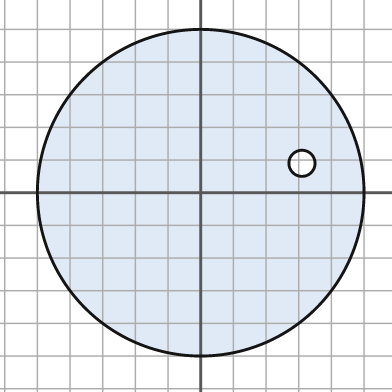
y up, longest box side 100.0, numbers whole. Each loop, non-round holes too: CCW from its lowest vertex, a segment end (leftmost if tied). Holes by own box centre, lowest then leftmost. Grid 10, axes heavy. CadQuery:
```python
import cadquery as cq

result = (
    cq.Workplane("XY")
    .moveTo(0.0, 0.0)
    .circle(50.0)
    .moveTo(31.0, 9.0)
    .circle(4.0)
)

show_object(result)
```